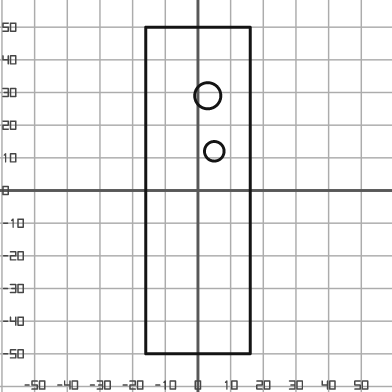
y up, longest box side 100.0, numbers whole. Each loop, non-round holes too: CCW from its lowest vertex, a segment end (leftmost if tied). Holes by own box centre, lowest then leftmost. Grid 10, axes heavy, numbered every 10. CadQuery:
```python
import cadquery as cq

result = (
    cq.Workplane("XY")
    .moveTo(-16.0, -50.0)
    .lineTo(16.0, -50.0)
    .lineTo(16.0, 50.0)
    .lineTo(-16.0, 50.0)
    .close()
    .moveTo(5.0, 12.0)
    .circle(3.0)
    .moveTo(3.0, 29.0)
    .circle(4.0)
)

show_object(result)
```